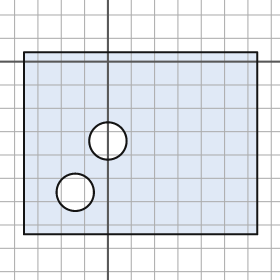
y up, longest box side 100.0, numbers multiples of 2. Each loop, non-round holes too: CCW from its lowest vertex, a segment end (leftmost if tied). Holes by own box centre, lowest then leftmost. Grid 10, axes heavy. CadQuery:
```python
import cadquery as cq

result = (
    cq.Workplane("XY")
    .moveTo(-36.0, -74.0)
    .lineTo(64.0, -74.0)
    .lineTo(64.0, 4.0)
    .lineTo(-36.0, 4.0)
    .close()
    .moveTo(-14.0, -56.0)
    .circle(8.0)
    .moveTo(0.0, -34.0)
    .circle(8.0)
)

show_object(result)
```